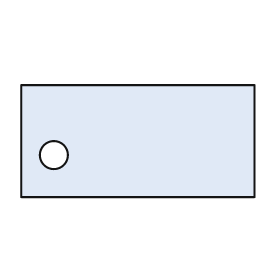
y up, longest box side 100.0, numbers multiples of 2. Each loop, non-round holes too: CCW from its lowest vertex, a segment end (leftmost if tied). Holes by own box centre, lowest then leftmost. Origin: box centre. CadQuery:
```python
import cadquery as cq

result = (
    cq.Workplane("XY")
    .moveTo(-50.0, -24.0)
    .lineTo(50.0, -24.0)
    .lineTo(50.0, 24.0)
    .lineTo(-50.0, 24.0)
    .close()
    .moveTo(-36.0, -6.0)
    .circle(6.0)
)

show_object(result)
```